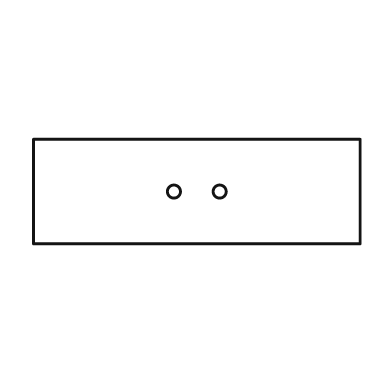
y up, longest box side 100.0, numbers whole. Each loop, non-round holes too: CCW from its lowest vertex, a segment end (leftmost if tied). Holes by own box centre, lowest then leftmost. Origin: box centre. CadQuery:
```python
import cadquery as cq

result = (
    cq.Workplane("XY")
    .moveTo(-50.0, -16.0)
    .lineTo(50.0, -16.0)
    .lineTo(50.0, 16.0)
    .lineTo(-50.0, 16.0)
    .close()
    .moveTo(-7.0, 0.0)
    .circle(2.0)
    .moveTo(7.0, 0.0)
    .circle(2.0)
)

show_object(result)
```